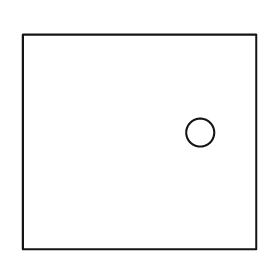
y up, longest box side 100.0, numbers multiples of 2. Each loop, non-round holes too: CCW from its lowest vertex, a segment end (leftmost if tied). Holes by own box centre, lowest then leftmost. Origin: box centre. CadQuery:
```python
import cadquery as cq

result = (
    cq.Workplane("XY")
    .moveTo(-50.0, -46.0)
    .lineTo(50.0, -46.0)
    .lineTo(50.0, 46.0)
    .lineTo(-50.0, 46.0)
    .close()
    .moveTo(26.0, 4.0)
    .circle(6.0)
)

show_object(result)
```